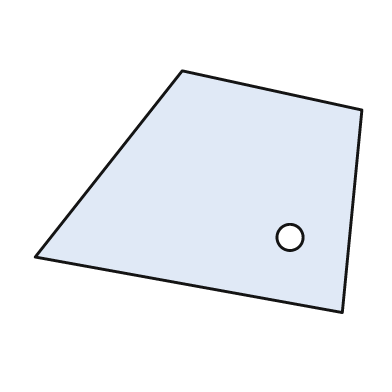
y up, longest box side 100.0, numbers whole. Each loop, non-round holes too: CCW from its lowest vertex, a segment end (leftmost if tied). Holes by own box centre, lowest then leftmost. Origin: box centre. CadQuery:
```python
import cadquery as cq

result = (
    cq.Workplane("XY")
    .moveTo(44.0, -37.0)
    .lineTo(50.0, 25.0)
    .lineTo(-5.0, 37.0)
    .lineTo(-50.0, -20.0)
    .close()
    .moveTo(28.0, -14.0)
    .circle(4.0)
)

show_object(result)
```